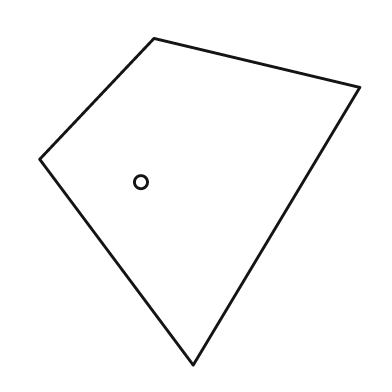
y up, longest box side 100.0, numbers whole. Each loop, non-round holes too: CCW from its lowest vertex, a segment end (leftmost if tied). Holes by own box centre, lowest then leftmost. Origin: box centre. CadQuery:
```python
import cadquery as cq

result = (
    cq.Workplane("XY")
    .moveTo(-2.0, -50.0)
    .lineTo(49.0, 35.0)
    .lineTo(-14.0, 50.0)
    .lineTo(-49.0, 13.0)
    .close()
    .moveTo(-18.0, 6.0)
    .circle(2.0)
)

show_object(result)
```